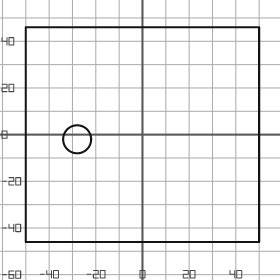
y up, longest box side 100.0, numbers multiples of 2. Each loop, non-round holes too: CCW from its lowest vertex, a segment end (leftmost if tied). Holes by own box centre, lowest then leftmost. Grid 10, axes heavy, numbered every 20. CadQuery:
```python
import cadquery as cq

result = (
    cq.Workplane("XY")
    .moveTo(-50.0, -46.0)
    .lineTo(50.0, -46.0)
    .lineTo(50.0, 46.0)
    .lineTo(-50.0, 46.0)
    .close()
    .moveTo(-28.0, -2.0)
    .circle(6.0)
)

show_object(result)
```